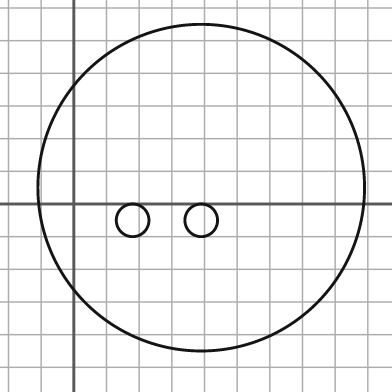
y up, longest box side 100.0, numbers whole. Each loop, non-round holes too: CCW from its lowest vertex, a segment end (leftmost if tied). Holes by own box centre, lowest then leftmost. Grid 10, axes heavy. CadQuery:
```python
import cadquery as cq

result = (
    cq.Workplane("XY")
    .moveTo(39.0, 5.0)
    .circle(50.0)
    .moveTo(18.0, -5.0)
    .circle(5.0)
    .moveTo(39.0, -5.0)
    .circle(5.0)
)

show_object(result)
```